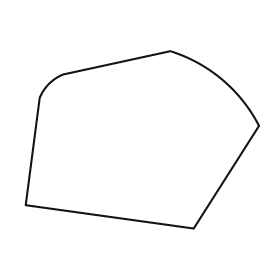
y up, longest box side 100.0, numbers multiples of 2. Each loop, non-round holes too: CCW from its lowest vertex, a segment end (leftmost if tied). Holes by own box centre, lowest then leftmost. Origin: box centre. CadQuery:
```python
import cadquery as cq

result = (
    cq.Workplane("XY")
    .moveTo(22.0, -38.0)
    .lineTo(50.0, 6.0)
    .threePointArc((34.0, 26.0), (12.0, 38.0))
    .lineTo(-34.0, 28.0)
    .threePointArc((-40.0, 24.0), (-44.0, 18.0))
    .lineTo(-50.0, -28.0)
    .close()
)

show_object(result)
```